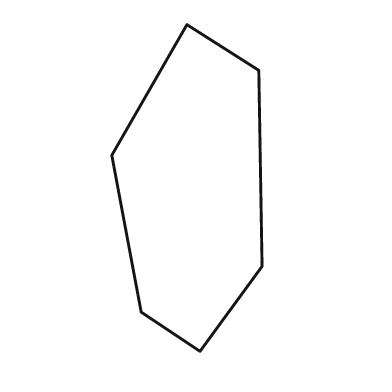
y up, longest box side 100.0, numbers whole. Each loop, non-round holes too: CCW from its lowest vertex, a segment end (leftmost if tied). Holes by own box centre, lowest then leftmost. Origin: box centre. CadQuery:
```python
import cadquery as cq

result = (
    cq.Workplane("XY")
    .moveTo(4.0, -50.0)
    .lineTo(23.0, -24.0)
    .lineTo(22.0, 36.0)
    .lineTo(0.0, 50.0)
    .lineTo(-23.0, 10.0)
    .lineTo(-14.0, -38.0)
    .close()
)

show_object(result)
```